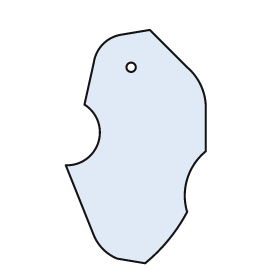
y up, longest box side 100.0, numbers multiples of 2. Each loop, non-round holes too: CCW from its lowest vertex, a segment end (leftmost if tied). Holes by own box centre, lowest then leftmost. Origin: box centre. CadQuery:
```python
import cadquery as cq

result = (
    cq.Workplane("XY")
    .moveTo(4.0, -50.0)
    .threePointArc((14.0, -40.0), (22.0, -28.0))
    .threePointArc((22.0, -14.0), (30.0, -2.0))
    .lineTo(30.0, 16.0)
    .threePointArc((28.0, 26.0), (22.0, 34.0))
    .lineTo(6.0, 50.0)
    .lineTo(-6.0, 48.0)
    .threePointArc((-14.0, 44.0), (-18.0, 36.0))
    .lineTo(-22.0, 18.0)
    .threePointArc((-16.0, 2.0), (-30.0, -8.0))
    .lineTo(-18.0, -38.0)
    .threePointArc((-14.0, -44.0), (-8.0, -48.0))
    .close()
    .moveTo(-2.0, 34.0)
    .circle(2.0)
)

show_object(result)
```